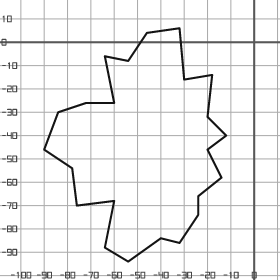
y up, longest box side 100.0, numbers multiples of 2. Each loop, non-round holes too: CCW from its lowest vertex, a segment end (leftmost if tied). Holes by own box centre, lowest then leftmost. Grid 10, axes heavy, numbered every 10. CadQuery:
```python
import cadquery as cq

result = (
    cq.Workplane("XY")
    .moveTo(-54.0, -94.0)
    .lineTo(-40.0, -84.0)
    .lineTo(-32.0, -86.0)
    .lineTo(-24.0, -74.0)
    .lineTo(-24.0, -66.0)
    .lineTo(-14.0, -58.0)
    .lineTo(-20.0, -46.0)
    .lineTo(-12.0, -40.0)
    .lineTo(-20.0, -32.0)
    .lineTo(-18.0, -14.0)
    .lineTo(-30.0, -16.0)
    .lineTo(-32.0, 6.0)
    .lineTo(-46.0, 4.0)
    .lineTo(-54.0, -8.0)
    .lineTo(-64.0, -6.0)
    .lineTo(-60.0, -26.0)
    .lineTo(-72.0, -26.0)
    .lineTo(-84.0, -30.0)
    .lineTo(-90.0, -46.0)
    .lineTo(-78.0, -54.0)
    .lineTo(-76.0, -70.0)
    .lineTo(-60.0, -68.0)
    .lineTo(-64.0, -88.0)
    .close()
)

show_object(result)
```